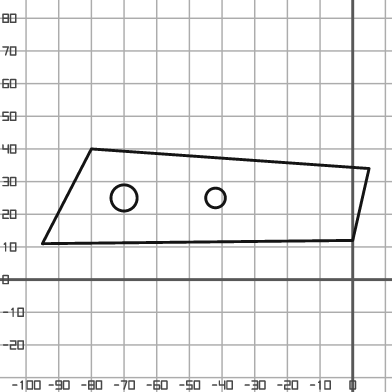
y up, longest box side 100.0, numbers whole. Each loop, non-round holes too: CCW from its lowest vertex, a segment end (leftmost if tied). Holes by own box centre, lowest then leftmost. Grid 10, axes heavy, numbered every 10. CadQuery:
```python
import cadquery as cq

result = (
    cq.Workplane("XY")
    .moveTo(-95.0, 11.0)
    .lineTo(0.0, 12.0)
    .lineTo(5.0, 34.0)
    .lineTo(-80.0, 40.0)
    .close()
    .moveTo(-70.0, 25.0)
    .circle(4.0)
    .moveTo(-42.0, 25.0)
    .circle(3.0)
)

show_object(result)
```